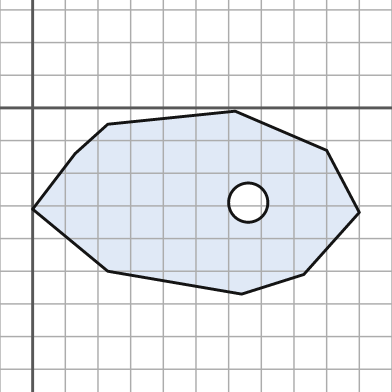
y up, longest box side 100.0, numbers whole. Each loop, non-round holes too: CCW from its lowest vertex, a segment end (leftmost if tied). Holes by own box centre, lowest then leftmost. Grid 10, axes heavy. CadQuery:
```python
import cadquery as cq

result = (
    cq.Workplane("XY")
    .moveTo(64.0, -57.0)
    .lineTo(83.0, -51.0)
    .lineTo(100.0, -32.0)
    .lineTo(90.0, -13.0)
    .lineTo(62.0, -1.0)
    .lineTo(23.0, -5.0)
    .lineTo(13.0, -14.0)
    .lineTo(0.0, -31.0)
    .lineTo(23.0, -50.0)
    .close()
    .moveTo(66.0, -29.0)
    .circle(6.0)
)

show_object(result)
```